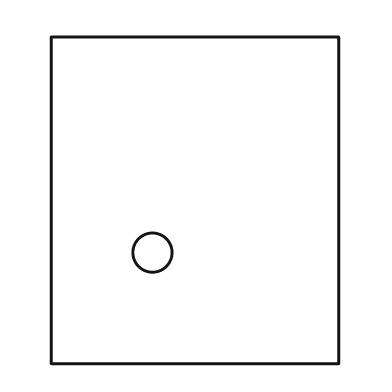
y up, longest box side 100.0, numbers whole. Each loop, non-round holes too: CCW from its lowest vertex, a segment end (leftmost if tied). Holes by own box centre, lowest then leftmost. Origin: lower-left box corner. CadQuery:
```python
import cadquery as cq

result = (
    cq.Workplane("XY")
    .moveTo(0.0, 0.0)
    .lineTo(88.0, 0.0)
    .lineTo(88.0, 100.0)
    .lineTo(0.0, 100.0)
    .close()
    .moveTo(31.0, 34.0)
    .circle(6.0)
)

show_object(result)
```